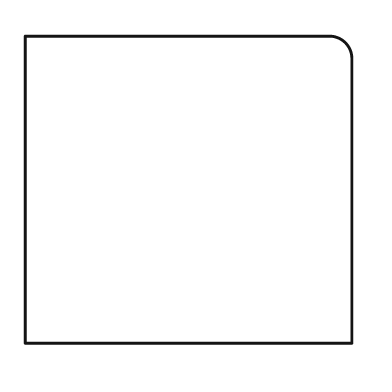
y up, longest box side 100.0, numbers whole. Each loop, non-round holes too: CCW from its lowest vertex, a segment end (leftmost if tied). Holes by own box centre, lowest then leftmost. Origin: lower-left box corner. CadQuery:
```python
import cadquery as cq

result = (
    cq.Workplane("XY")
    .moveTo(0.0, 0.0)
    .lineTo(100.0, 0.0)
    .lineTo(100.0, 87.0)
    .threePointArc((98.0, 92.0), (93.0, 94.0))
    .lineTo(0.0, 94.0)
    .close()
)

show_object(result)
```